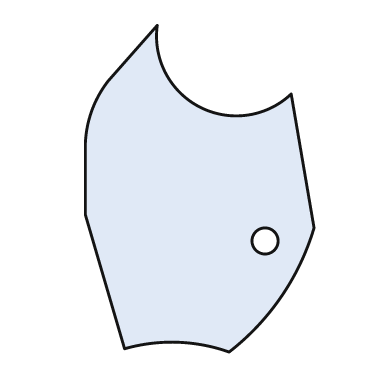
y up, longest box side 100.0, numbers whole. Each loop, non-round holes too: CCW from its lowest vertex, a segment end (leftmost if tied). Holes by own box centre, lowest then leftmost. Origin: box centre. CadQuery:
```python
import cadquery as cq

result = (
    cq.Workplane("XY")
    .moveTo(9.0, -50.0)
    .threePointArc((25.0, -33.0), (35.0, -12.0))
    .lineTo(28.0, 29.0)
    .threePointArc((0.0, 25.0), (-13.0, 50.0))
    .lineTo(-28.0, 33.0)
    .threePointArc((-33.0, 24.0), (-35.0, 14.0))
    .lineTo(-35.0, -8.0)
    .lineTo(-23.0, -49.0)
    .threePointArc((-7.0, -47.0), (9.0, -50.0))
    .close()
    .moveTo(20.0, -16.0)
    .circle(4.0)
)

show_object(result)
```